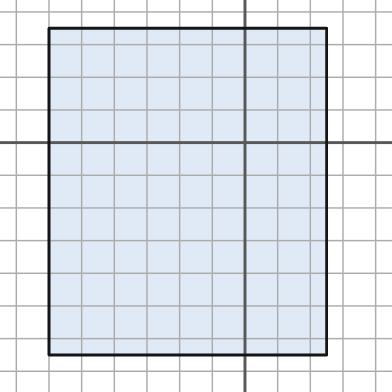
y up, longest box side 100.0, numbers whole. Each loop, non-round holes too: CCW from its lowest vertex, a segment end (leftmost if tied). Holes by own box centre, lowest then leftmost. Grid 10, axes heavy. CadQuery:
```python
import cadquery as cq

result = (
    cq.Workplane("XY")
    .moveTo(-60.0, -65.0)
    .lineTo(25.0, -65.0)
    .lineTo(25.0, 35.0)
    .lineTo(-60.0, 35.0)
    .close()
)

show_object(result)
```